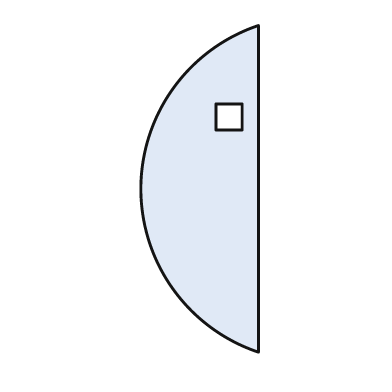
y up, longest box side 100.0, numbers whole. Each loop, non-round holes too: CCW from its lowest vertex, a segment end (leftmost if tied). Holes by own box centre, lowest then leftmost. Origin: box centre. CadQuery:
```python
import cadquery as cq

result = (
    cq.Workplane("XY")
    .moveTo(18.0, -50.0)
    .lineTo(18.0, 50.0)
    .threePointArc((-18.0, 0.0), (18.0, -50.0))
    .close()
    .moveTo(5.0, 18.0)
    .lineTo(13.0, 18.0)
    .lineTo(13.0, 26.0)
    .lineTo(5.0, 26.0)
    .close()
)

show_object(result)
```